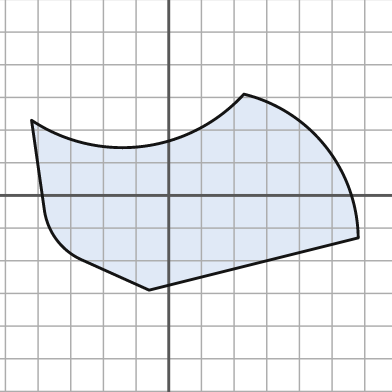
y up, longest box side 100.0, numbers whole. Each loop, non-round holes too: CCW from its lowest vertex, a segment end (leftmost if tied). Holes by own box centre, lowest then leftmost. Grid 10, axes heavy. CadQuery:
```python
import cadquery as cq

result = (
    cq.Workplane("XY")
    .moveTo(-6.0, -29.0)
    .lineTo(58.0, -13.0)
    .threePointArc((48.0, 15.0), (23.0, 31.0))
    .threePointArc((-8.0, 15.0), (-42.0, 23.0))
    .lineTo(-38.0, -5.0)
    .threePointArc((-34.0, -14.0), (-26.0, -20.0))
    .close()
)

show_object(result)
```